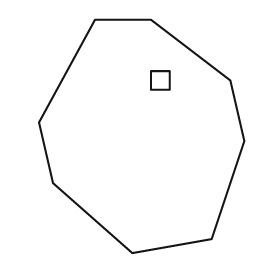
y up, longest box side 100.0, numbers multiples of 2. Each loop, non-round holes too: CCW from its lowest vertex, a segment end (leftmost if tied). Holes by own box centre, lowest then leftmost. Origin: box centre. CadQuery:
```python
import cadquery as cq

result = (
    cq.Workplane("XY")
    .moveTo(-4.0, -50.0)
    .lineTo(30.0, -44.0)
    .lineTo(44.0, -2.0)
    .lineTo(38.0, 24.0)
    .lineTo(4.0, 50.0)
    .lineTo(-20.0, 50.0)
    .lineTo(-44.0, 6.0)
    .lineTo(-38.0, -20.0)
    .close()
    .moveTo(4.0, 20.0)
    .lineTo(12.0, 20.0)
    .lineTo(12.0, 28.0)
    .lineTo(4.0, 28.0)
    .close()
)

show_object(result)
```